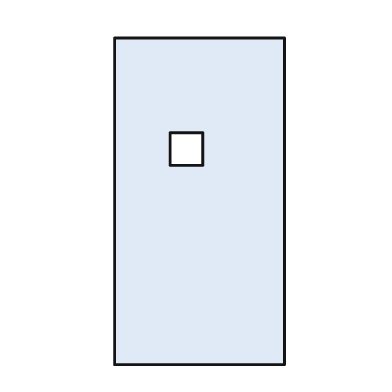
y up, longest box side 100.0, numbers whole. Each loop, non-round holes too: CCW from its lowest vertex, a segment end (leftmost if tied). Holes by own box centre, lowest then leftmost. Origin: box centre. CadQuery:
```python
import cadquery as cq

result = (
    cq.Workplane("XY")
    .moveTo(-26.0, -50.0)
    .lineTo(26.0, -50.0)
    .lineTo(26.0, 50.0)
    .lineTo(-26.0, 50.0)
    .close()
    .moveTo(-9.0, 11.0)
    .lineTo(1.0, 11.0)
    .lineTo(1.0, 21.0)
    .lineTo(-9.0, 21.0)
    .close()
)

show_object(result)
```